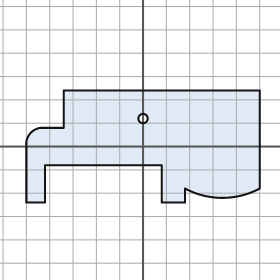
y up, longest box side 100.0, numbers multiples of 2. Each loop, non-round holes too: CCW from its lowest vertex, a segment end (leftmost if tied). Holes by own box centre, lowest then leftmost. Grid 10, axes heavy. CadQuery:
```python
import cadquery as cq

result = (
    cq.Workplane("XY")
    .moveTo(-50.0, -24.0)
    .lineTo(-42.0, -24.0)
    .lineTo(-42.0, -8.0)
    .lineTo(8.0, -8.0)
    .lineTo(8.0, -24.0)
    .lineTo(18.0, -24.0)
    .lineTo(18.0, -18.0)
    .threePointArc((34.0, -22.0), (50.0, -18.0))
    .lineTo(50.0, 24.0)
    .lineTo(-34.0, 24.0)
    .lineTo(-34.0, 8.0)
    .lineTo(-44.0, 8.0)
    .threePointArc((-48.0, 6.0), (-50.0, 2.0))
    .close()
    .moveTo(0.0, 12.0)
    .circle(2.0)
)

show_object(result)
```